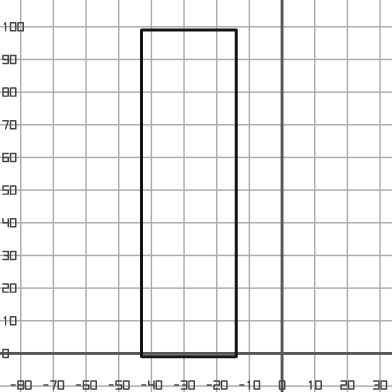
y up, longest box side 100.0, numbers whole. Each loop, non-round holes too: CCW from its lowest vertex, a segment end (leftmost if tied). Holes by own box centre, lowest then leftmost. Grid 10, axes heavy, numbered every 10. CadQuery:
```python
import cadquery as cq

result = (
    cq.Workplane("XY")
    .moveTo(-43.0, -1.0)
    .lineTo(-14.0, -1.0)
    .lineTo(-14.0, 99.0)
    .lineTo(-43.0, 99.0)
    .close()
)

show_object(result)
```